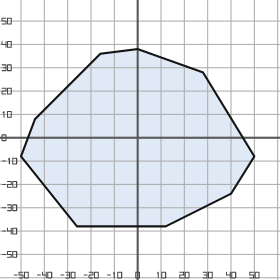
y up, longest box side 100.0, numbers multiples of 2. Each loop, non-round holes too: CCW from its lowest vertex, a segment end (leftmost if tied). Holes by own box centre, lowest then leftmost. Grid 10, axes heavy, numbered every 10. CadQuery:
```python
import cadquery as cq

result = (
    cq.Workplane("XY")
    .moveTo(-26.0, -38.0)
    .lineTo(12.0, -38.0)
    .lineTo(40.0, -24.0)
    .lineTo(50.0, -8.0)
    .lineTo(28.0, 28.0)
    .lineTo(0.0, 38.0)
    .lineTo(-16.0, 36.0)
    .lineTo(-44.0, 8.0)
    .lineTo(-50.0, -8.0)
    .close()
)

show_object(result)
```